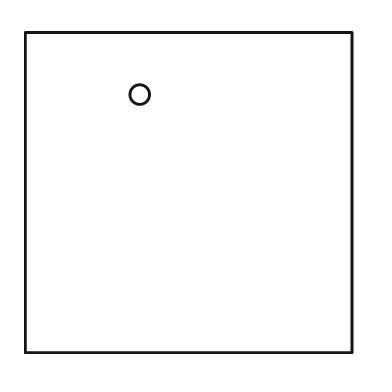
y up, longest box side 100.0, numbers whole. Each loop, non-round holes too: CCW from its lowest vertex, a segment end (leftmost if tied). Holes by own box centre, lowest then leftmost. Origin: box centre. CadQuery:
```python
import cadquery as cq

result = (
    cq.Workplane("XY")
    .moveTo(-50.0, -49.0)
    .lineTo(50.0, -49.0)
    .lineTo(50.0, 49.0)
    .lineTo(-50.0, 49.0)
    .close()
    .moveTo(-15.0, 30.0)
    .circle(3.0)
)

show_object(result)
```